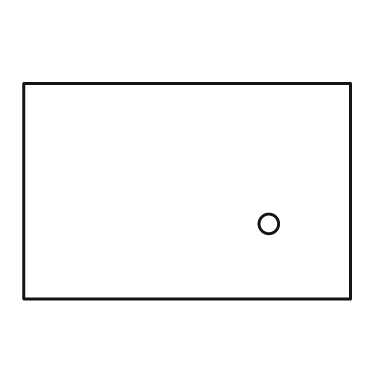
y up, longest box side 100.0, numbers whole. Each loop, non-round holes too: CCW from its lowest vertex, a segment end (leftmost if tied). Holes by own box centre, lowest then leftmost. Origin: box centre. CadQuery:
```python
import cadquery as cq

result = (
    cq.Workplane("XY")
    .moveTo(-50.0, -33.0)
    .lineTo(50.0, -33.0)
    .lineTo(50.0, 33.0)
    .lineTo(-50.0, 33.0)
    .close()
    .moveTo(25.0, -10.0)
    .circle(3.0)
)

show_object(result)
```